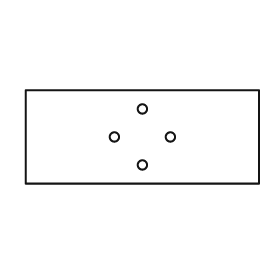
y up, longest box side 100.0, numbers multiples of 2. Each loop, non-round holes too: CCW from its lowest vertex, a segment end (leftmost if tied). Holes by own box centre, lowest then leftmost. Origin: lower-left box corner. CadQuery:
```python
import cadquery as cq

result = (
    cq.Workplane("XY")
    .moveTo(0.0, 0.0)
    .lineTo(100.0, 0.0)
    .lineTo(100.0, 40.0)
    .lineTo(0.0, 40.0)
    .close()
    .moveTo(50.0, 8.0)
    .circle(2.0)
    .moveTo(38.0, 20.0)
    .circle(2.0)
    .moveTo(62.0, 20.0)
    .circle(2.0)
    .moveTo(50.0, 32.0)
    .circle(2.0)
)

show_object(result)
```